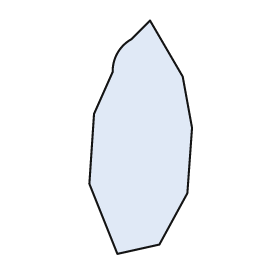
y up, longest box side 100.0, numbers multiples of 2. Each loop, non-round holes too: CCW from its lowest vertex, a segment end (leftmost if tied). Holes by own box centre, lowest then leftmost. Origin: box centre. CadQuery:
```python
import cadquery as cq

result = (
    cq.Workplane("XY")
    .moveTo(-10.0, -50.0)
    .lineTo(8.0, -46.0)
    .lineTo(20.0, -24.0)
    .lineTo(22.0, 4.0)
    .lineTo(18.0, 26.0)
    .lineTo(4.0, 50.0)
    .lineTo(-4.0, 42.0)
    .threePointArc((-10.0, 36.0), (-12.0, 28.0))
    .lineTo(-20.0, 10.0)
    .lineTo(-22.0, -20.0)
    .close()
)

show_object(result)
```